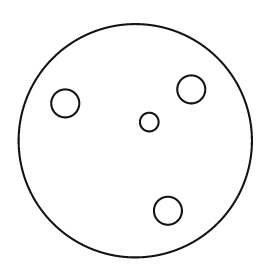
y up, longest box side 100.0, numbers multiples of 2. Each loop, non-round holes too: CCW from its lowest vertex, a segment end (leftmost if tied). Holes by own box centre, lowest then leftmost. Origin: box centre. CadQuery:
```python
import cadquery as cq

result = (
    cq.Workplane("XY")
    .moveTo(0.0, 0.0)
    .circle(50.0)
    .moveTo(14.0, -30.0)
    .circle(6.0)
    .moveTo(6.0, 8.0)
    .circle(4.0)
    .moveTo(-30.0, 16.0)
    .circle(6.0)
    .moveTo(24.0, 22.0)
    .circle(6.0)
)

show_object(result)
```